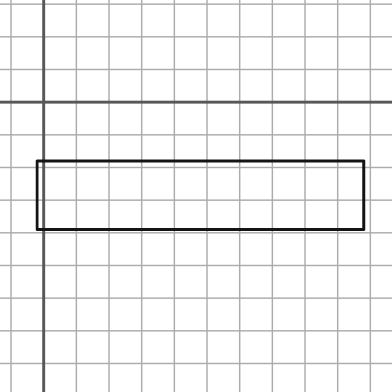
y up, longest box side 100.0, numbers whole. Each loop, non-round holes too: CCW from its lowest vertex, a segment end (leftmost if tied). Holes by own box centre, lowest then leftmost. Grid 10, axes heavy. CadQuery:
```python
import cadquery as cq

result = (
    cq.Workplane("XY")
    .moveTo(-2.0, -39.0)
    .lineTo(98.0, -39.0)
    .lineTo(98.0, -18.0)
    .lineTo(-2.0, -18.0)
    .close()
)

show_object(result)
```